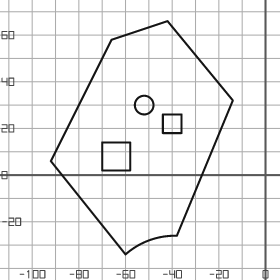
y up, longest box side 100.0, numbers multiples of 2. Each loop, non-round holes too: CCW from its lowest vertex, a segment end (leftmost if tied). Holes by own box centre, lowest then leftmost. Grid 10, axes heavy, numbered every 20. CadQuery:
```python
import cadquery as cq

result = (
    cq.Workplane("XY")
    .moveTo(-60.0, -34.0)
    .threePointArc((-50.0, -28.0), (-38.0, -26.0))
    .lineTo(-14.0, 32.0)
    .lineTo(-42.0, 66.0)
    .lineTo(-66.0, 58.0)
    .lineTo(-92.0, 6.0)
    .close()
    .moveTo(-70.0, 2.0)
    .lineTo(-58.0, 2.0)
    .lineTo(-58.0, 14.0)
    .lineTo(-70.0, 14.0)
    .close()
    .moveTo(-44.0, 18.0)
    .lineTo(-36.0, 18.0)
    .lineTo(-36.0, 26.0)
    .lineTo(-44.0, 26.0)
    .close()
    .moveTo(-52.0, 30.0)
    .circle(4.0)
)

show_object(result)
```